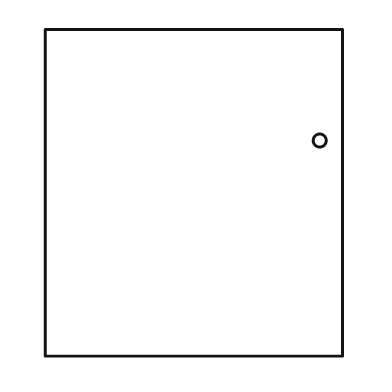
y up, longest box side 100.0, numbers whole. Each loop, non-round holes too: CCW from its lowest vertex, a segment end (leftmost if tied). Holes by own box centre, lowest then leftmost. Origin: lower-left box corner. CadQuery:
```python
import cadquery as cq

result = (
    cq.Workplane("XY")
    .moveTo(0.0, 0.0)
    .lineTo(91.0, 0.0)
    .lineTo(91.0, 100.0)
    .lineTo(0.0, 100.0)
    .close()
    .moveTo(84.0, 66.0)
    .circle(2.0)
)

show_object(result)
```